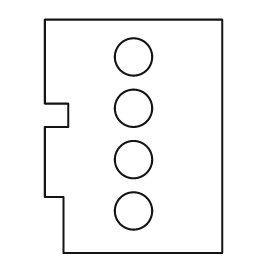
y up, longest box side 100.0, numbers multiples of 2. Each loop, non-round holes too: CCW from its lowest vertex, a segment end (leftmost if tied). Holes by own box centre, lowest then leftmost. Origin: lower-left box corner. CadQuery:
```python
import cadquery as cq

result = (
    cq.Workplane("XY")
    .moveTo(8.0, 0.0)
    .lineTo(76.0, 0.0)
    .lineTo(76.0, 100.0)
    .lineTo(0.0, 100.0)
    .lineTo(0.0, 64.0)
    .lineTo(10.0, 64.0)
    .lineTo(10.0, 54.0)
    .lineTo(0.0, 54.0)
    .lineTo(0.0, 24.0)
    .lineTo(8.0, 24.0)
    .close()
    .moveTo(38.0, 18.0)
    .circle(8.0)
    .moveTo(38.0, 40.0)
    .circle(8.0)
    .moveTo(38.0, 62.0)
    .circle(8.0)
    .moveTo(38.0, 84.0)
    .circle(8.0)
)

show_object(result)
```